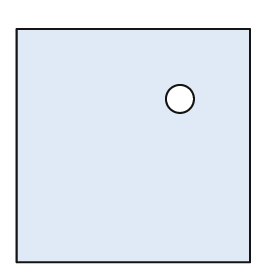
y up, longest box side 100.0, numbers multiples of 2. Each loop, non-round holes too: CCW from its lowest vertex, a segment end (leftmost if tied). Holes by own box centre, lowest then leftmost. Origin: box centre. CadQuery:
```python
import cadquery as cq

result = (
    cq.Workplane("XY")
    .moveTo(-50.0, -50.0)
    .lineTo(50.0, -50.0)
    .lineTo(50.0, 50.0)
    .lineTo(-50.0, 50.0)
    .close()
    .moveTo(20.0, 20.0)
    .circle(6.0)
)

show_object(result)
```